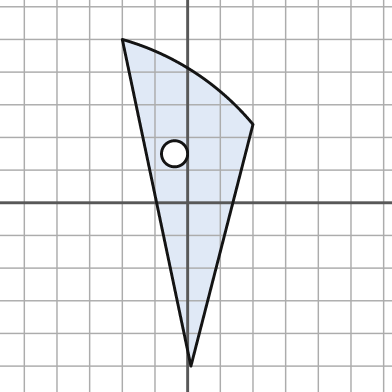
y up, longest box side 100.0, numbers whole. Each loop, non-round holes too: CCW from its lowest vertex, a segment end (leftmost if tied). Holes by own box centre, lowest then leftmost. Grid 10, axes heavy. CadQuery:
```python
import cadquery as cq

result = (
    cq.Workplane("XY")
    .moveTo(1.0, -50.0)
    .lineTo(20.0, 24.0)
    .threePointArc((2.0, 40.0), (-20.0, 50.0))
    .close()
    .moveTo(-4.0, 15.0)
    .circle(4.0)
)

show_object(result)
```